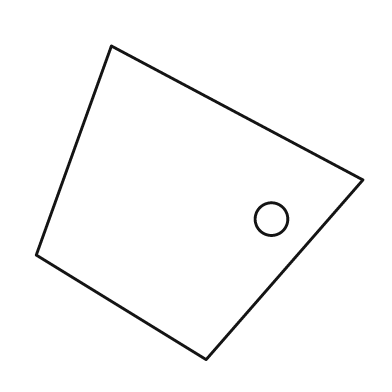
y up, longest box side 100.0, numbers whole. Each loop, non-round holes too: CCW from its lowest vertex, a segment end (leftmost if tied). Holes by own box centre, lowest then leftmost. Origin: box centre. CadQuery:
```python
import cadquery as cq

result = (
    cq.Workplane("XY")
    .moveTo(2.0, -48.0)
    .lineTo(50.0, 7.0)
    .lineTo(-27.0, 48.0)
    .lineTo(-50.0, -16.0)
    .close()
    .moveTo(22.0, -5.0)
    .circle(5.0)
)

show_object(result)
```